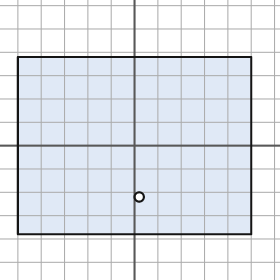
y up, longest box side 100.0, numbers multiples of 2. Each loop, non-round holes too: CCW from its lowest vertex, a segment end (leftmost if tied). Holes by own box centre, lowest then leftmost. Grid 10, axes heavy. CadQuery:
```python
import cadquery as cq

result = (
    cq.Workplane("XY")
    .moveTo(-50.0, -38.0)
    .lineTo(50.0, -38.0)
    .lineTo(50.0, 38.0)
    .lineTo(-50.0, 38.0)
    .close()
    .moveTo(2.0, -22.0)
    .circle(2.0)
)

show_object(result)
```